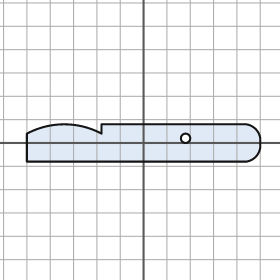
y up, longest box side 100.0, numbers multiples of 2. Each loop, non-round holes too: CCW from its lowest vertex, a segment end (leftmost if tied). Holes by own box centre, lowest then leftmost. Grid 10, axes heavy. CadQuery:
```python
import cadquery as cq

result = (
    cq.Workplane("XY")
    .moveTo(-50.0, -8.0)
    .lineTo(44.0, -8.0)
    .threePointArc((48.0, -6.0), (50.0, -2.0))
    .lineTo(50.0, 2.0)
    .threePointArc((48.0, 6.0), (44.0, 8.0))
    .lineTo(-18.0, 8.0)
    .lineTo(-18.0, 4.0)
    .threePointArc((-34.0, 8.0), (-50.0, 4.0))
    .close()
    .moveTo(18.0, 2.0)
    .circle(2.0)
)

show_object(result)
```